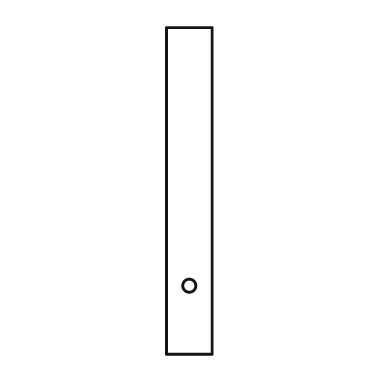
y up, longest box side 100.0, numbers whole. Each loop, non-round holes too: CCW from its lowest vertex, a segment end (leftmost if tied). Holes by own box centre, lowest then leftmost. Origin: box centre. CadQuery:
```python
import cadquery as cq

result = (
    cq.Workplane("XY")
    .moveTo(-7.0, -50.0)
    .lineTo(7.0, -50.0)
    .lineTo(7.0, 50.0)
    .lineTo(-7.0, 50.0)
    .close()
    .moveTo(0.0, -29.0)
    .circle(2.0)
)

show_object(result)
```